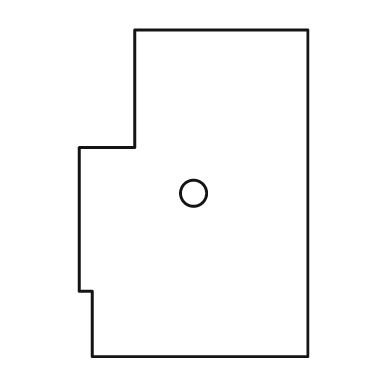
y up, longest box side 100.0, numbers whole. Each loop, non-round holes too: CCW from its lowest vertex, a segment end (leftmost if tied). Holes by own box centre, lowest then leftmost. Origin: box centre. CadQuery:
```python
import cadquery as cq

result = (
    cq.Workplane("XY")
    .moveTo(-31.0, -50.0)
    .lineTo(35.0, -50.0)
    .lineTo(35.0, 50.0)
    .lineTo(-18.0, 50.0)
    .lineTo(-18.0, 14.0)
    .lineTo(-35.0, 14.0)
    .lineTo(-35.0, -30.0)
    .lineTo(-31.0, -30.0)
    .close()
    .moveTo(0.0, 0.0)
    .circle(4.0)
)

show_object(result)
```